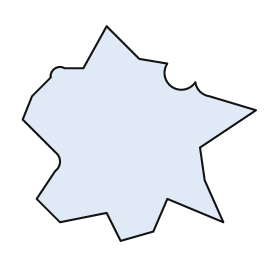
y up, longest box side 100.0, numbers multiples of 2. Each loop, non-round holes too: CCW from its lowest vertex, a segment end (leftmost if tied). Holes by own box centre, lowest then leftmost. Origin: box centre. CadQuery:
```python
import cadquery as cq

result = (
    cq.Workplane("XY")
    .moveTo(-8.0, -46.0)
    .lineTo(6.0, -42.0)
    .lineTo(12.0, -28.0)
    .lineTo(36.0, -38.0)
    .lineTo(28.0, -20.0)
    .lineTo(26.0, -6.0)
    .lineTo(50.0, 10.0)
    .lineTo(30.0, 16.0)
    .threePointArc((26.0, 18.0), (24.0, 22.0))
    .threePointArc((14.0, 20.0), (12.0, 30.0))
    .lineTo(0.0, 32.0)
    .lineTo(-14.0, 46.0)
    .lineTo(-24.0, 28.0)
    .lineTo(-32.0, 28.0)
    .threePointArc((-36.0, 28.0), (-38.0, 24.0))
    .lineTo(-46.0, 16.0)
    .lineTo(-50.0, 6.0)
    .lineTo(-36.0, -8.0)
    .threePointArc((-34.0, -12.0), (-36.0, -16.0))
    .lineTo(-44.0, -28.0)
    .lineTo(-34.0, -38.0)
    .lineTo(-14.0, -34.0)
    .close()
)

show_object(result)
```